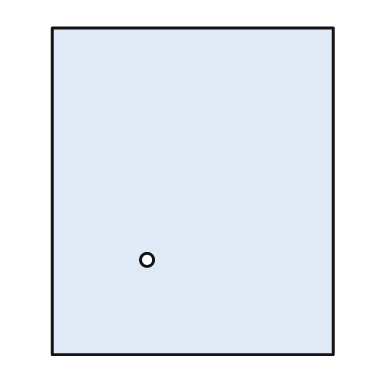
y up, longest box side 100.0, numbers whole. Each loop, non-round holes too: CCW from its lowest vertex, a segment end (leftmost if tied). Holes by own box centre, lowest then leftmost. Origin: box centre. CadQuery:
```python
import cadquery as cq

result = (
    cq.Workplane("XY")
    .moveTo(-43.0, -50.0)
    .lineTo(43.0, -50.0)
    .lineTo(43.0, 50.0)
    .lineTo(-43.0, 50.0)
    .close()
    .moveTo(-14.0, -21.0)
    .circle(2.0)
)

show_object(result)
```